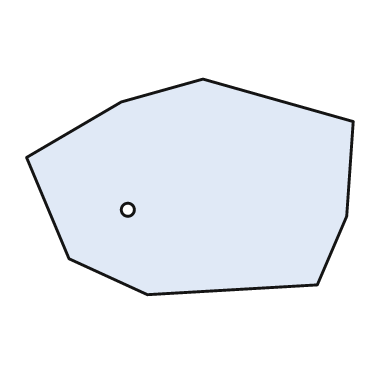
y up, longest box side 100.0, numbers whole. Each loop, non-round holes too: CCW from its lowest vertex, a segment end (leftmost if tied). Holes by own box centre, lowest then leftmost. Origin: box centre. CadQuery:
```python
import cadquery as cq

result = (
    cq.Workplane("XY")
    .moveTo(-13.0, -33.0)
    .lineTo(39.0, -30.0)
    .lineTo(48.0, -9.0)
    .lineTo(50.0, 20.0)
    .lineTo(4.0, 33.0)
    .lineTo(-21.0, 26.0)
    .lineTo(-50.0, 9.0)
    .lineTo(-37.0, -22.0)
    .close()
    .moveTo(-19.0, -7.0)
    .circle(2.0)
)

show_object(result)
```